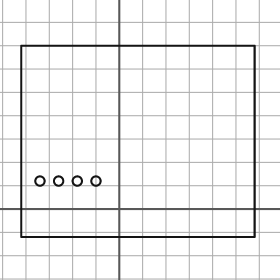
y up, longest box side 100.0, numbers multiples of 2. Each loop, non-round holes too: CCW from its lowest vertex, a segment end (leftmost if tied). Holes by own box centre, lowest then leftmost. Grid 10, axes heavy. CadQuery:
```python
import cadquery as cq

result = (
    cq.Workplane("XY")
    .moveTo(-42.0, -12.0)
    .lineTo(58.0, -12.0)
    .lineTo(58.0, 70.0)
    .lineTo(-42.0, 70.0)
    .close()
    .moveTo(-34.0, 12.0)
    .circle(2.0)
    .moveTo(-26.0, 12.0)
    .circle(2.0)
    .moveTo(-18.0, 12.0)
    .circle(2.0)
    .moveTo(-10.0, 12.0)
    .circle(2.0)
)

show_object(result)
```